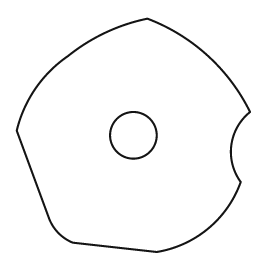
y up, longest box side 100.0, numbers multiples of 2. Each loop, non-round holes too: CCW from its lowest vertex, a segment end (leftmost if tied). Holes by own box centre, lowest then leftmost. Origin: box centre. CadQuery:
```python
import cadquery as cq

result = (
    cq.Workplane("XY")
    .moveTo(10.0, -50.0)
    .threePointArc((32.0, -40.0), (46.0, -20.0))
    .threePointArc((42.0, -4.0), (50.0, 10.0))
    .threePointArc((32.0, 34.0), (6.0, 50.0))
    .threePointArc((-12.0, 44.0), (-28.0, 34.0))
    .threePointArc((-42.0, 20.0), (-50.0, 2.0))
    .lineTo(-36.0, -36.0)
    .threePointArc((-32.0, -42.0), (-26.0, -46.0))
    .close()
    .moveTo(0.0, 0.0)
    .circle(10.0)
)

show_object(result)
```